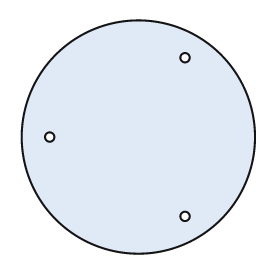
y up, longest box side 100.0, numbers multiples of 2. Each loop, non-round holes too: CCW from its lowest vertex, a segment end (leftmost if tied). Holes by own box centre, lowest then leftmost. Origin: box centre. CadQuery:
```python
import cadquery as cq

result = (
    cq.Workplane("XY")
    .moveTo(0.0, 0.0)
    .circle(50.0)
    .moveTo(20.0, -34.0)
    .circle(2.0)
    .moveTo(-38.0, 0.0)
    .circle(2.0)
    .moveTo(20.0, 34.0)
    .circle(2.0)
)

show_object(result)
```